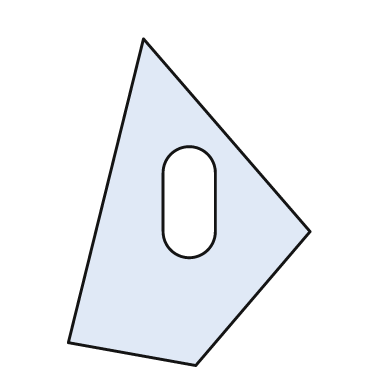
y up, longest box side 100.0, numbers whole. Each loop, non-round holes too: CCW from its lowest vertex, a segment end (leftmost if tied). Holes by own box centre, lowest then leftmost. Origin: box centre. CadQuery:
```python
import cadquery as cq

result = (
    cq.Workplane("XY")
    .moveTo(2.0, -50.0)
    .lineTo(37.0, -9.0)
    .lineTo(-14.0, 50.0)
    .lineTo(-37.0, -43.0)
    .close()
    .moveTo(-8.0, -9.0)
    .threePointArc((0.0, -17.0), (8.0, -9.0))
    .lineTo(8.0, 9.0)
    .threePointArc((0.0, 17.0), (-8.0, 9.0))
    .close()
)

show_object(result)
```